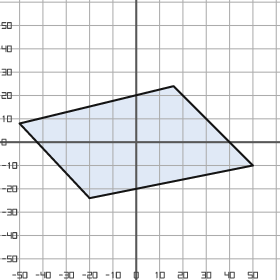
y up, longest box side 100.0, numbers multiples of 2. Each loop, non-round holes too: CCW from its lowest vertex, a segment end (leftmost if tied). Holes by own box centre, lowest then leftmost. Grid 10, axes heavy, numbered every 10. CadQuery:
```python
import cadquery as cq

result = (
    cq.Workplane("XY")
    .moveTo(-20.0, -24.0)
    .lineTo(50.0, -10.0)
    .lineTo(16.0, 24.0)
    .lineTo(-50.0, 8.0)
    .close()
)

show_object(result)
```